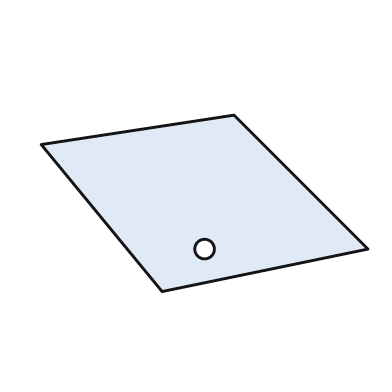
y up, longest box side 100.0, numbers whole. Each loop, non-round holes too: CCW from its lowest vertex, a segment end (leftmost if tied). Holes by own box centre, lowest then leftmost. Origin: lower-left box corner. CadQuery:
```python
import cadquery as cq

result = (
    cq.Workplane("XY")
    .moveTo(37.0, 0.0)
    .lineTo(100.0, 13.0)
    .lineTo(59.0, 54.0)
    .lineTo(0.0, 45.0)
    .close()
    .moveTo(50.0, 13.0)
    .circle(3.0)
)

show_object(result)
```